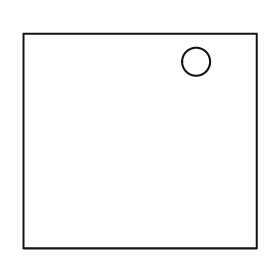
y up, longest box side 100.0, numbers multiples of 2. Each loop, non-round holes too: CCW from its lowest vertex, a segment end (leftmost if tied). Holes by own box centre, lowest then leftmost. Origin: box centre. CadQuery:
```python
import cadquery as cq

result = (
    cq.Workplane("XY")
    .moveTo(-50.0, -46.0)
    .lineTo(50.0, -46.0)
    .lineTo(50.0, 46.0)
    .lineTo(-50.0, 46.0)
    .close()
    .moveTo(24.0, 34.0)
    .circle(6.0)
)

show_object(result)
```